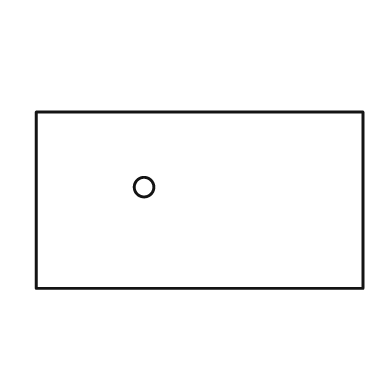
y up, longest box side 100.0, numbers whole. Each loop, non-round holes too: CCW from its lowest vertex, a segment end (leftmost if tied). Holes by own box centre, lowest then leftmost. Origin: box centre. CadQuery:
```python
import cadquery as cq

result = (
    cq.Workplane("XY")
    .moveTo(-50.0, -27.0)
    .lineTo(50.0, -27.0)
    .lineTo(50.0, 27.0)
    .lineTo(-50.0, 27.0)
    .close()
    .moveTo(-17.0, 4.0)
    .circle(3.0)
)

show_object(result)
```